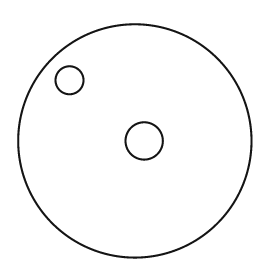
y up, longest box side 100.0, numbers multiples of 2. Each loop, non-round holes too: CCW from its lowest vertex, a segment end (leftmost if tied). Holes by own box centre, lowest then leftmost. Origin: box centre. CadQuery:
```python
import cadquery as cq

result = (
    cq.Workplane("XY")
    .moveTo(0.0, 0.0)
    .circle(50.0)
    .moveTo(4.0, 0.0)
    .circle(8.0)
    .moveTo(-28.0, 26.0)
    .circle(6.0)
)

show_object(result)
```